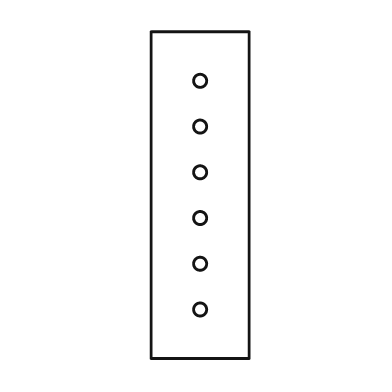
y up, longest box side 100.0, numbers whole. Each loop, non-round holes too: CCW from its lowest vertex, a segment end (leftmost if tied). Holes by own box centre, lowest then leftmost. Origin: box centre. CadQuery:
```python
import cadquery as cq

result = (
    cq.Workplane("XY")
    .moveTo(-15.0, -50.0)
    .lineTo(15.0, -50.0)
    .lineTo(15.0, 50.0)
    .lineTo(-15.0, 50.0)
    .close()
    .moveTo(0.0, -35.0)
    .circle(2.0)
    .moveTo(0.0, -21.0)
    .circle(2.0)
    .moveTo(0.0, -7.0)
    .circle(2.0)
    .moveTo(0.0, 7.0)
    .circle(2.0)
    .moveTo(0.0, 21.0)
    .circle(2.0)
    .moveTo(0.0, 35.0)
    .circle(2.0)
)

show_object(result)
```